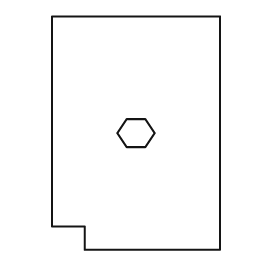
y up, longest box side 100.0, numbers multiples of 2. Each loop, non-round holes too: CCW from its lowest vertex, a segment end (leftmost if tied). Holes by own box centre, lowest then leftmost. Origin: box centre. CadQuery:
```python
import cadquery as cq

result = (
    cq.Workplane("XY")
    .moveTo(-22.0, -50.0)
    .lineTo(36.0, -50.0)
    .lineTo(36.0, 50.0)
    .lineTo(-36.0, 50.0)
    .lineTo(-36.0, -40.0)
    .lineTo(-22.0, -40.0)
    .close()
    .moveTo(-4.0, -6.0)
    .lineTo(4.0, -6.0)
    .lineTo(8.0, 0.0)
    .lineTo(4.0, 6.0)
    .lineTo(-4.0, 6.0)
    .lineTo(-8.0, 0.0)
    .close()
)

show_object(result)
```